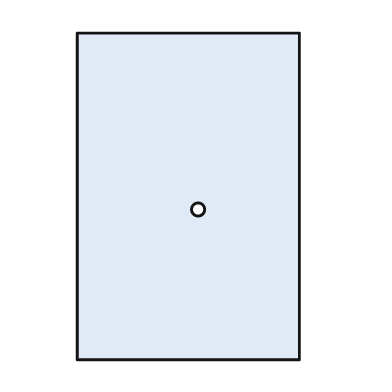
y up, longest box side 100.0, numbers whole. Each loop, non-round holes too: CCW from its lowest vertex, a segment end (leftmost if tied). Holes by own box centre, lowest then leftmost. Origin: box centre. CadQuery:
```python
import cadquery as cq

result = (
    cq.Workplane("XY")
    .moveTo(-34.0, -50.0)
    .lineTo(34.0, -50.0)
    .lineTo(34.0, 50.0)
    .lineTo(-34.0, 50.0)
    .close()
    .moveTo(3.0, -4.0)
    .circle(2.0)
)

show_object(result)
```